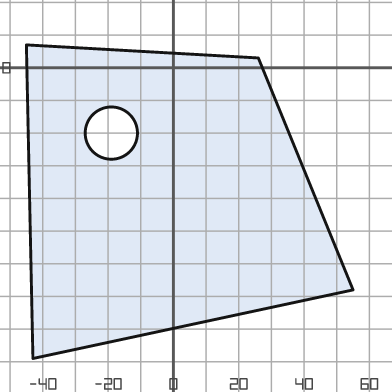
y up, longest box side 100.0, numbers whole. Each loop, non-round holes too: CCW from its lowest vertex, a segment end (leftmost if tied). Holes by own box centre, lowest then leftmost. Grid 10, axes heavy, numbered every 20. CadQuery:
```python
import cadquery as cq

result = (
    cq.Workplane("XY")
    .moveTo(-43.0, -89.0)
    .lineTo(55.0, -68.0)
    .lineTo(26.0, 3.0)
    .lineTo(-45.0, 7.0)
    .close()
    .moveTo(-19.0, -20.0)
    .circle(8.0)
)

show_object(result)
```